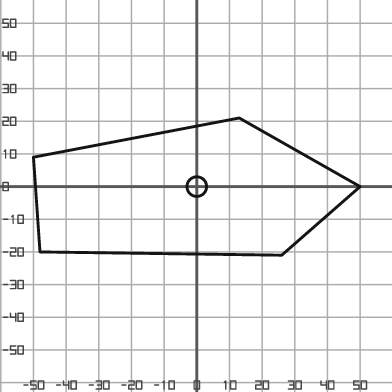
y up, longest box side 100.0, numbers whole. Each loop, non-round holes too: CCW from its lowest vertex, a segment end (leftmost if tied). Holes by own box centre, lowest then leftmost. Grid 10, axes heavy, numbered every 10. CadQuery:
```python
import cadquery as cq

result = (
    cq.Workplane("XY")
    .moveTo(26.0, -21.0)
    .lineTo(50.0, 0.0)
    .lineTo(13.0, 21.0)
    .lineTo(-50.0, 9.0)
    .lineTo(-48.0, -20.0)
    .close()
    .moveTo(0.0, 0.0)
    .circle(3.0)
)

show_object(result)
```